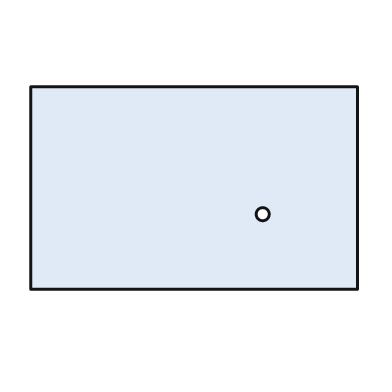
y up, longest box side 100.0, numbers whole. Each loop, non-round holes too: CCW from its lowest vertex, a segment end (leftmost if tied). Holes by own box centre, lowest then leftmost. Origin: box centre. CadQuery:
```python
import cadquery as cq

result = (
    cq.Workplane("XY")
    .moveTo(-50.0, -31.0)
    .lineTo(50.0, -31.0)
    .lineTo(50.0, 31.0)
    .lineTo(-50.0, 31.0)
    .close()
    .moveTo(21.0, -8.0)
    .circle(2.0)
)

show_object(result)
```